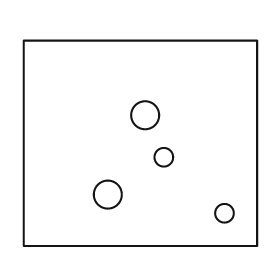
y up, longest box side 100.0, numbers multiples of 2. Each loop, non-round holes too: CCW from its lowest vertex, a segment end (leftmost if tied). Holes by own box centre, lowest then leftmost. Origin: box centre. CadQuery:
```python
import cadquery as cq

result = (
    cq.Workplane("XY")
    .moveTo(-50.0, -44.0)
    .lineTo(50.0, -44.0)
    .lineTo(50.0, 44.0)
    .lineTo(-50.0, 44.0)
    .close()
    .moveTo(36.0, -30.0)
    .circle(4.0)
    .moveTo(-14.0, -22.0)
    .circle(6.0)
    .moveTo(10.0, -6.0)
    .circle(4.0)
    .moveTo(2.0, 12.0)
    .circle(6.0)
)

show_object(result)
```